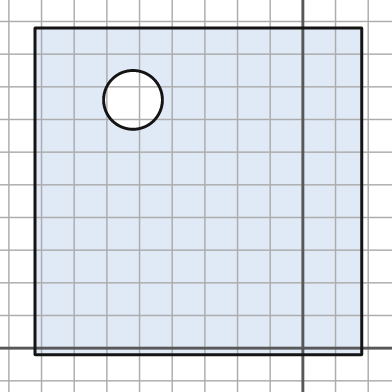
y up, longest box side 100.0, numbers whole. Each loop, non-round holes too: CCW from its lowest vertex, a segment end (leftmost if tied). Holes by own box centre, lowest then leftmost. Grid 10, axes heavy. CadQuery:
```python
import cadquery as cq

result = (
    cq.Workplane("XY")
    .moveTo(-82.0, -2.0)
    .lineTo(18.0, -2.0)
    .lineTo(18.0, 98.0)
    .lineTo(-82.0, 98.0)
    .close()
    .moveTo(-52.0, 76.0)
    .circle(9.0)
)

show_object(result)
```